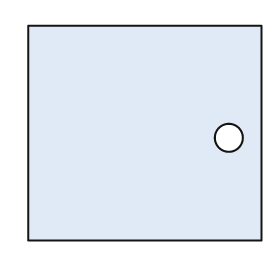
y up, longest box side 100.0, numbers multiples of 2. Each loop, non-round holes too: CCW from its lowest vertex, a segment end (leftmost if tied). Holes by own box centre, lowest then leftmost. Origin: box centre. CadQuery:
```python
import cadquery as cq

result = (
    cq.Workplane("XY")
    .moveTo(-50.0, -46.0)
    .lineTo(50.0, -46.0)
    .lineTo(50.0, 46.0)
    .lineTo(-50.0, 46.0)
    .close()
    .moveTo(36.0, -2.0)
    .circle(6.0)
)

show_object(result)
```